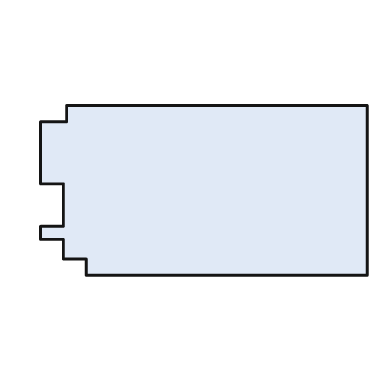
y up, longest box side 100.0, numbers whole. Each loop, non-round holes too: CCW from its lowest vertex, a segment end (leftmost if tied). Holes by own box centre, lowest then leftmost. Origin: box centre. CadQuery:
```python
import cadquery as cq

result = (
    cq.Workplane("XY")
    .moveTo(-36.0, -26.0)
    .lineTo(50.0, -26.0)
    .lineTo(50.0, 26.0)
    .lineTo(-42.0, 26.0)
    .lineTo(-42.0, 21.0)
    .lineTo(-50.0, 21.0)
    .lineTo(-50.0, 2.0)
    .lineTo(-43.0, 2.0)
    .lineTo(-43.0, -11.0)
    .lineTo(-50.0, -11.0)
    .lineTo(-50.0, -15.0)
    .lineTo(-43.0, -15.0)
    .lineTo(-43.0, -21.0)
    .lineTo(-36.0, -21.0)
    .close()
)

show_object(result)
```